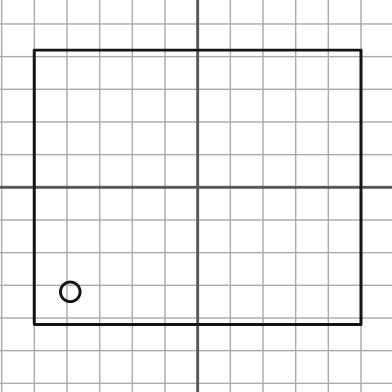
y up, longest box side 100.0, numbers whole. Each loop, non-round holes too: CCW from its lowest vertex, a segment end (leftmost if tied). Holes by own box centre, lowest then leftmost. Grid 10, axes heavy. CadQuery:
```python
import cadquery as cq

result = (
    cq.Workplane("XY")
    .moveTo(-50.0, -42.0)
    .lineTo(50.0, -42.0)
    .lineTo(50.0, 42.0)
    .lineTo(-50.0, 42.0)
    .close()
    .moveTo(-39.0, -32.0)
    .circle(3.0)
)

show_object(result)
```